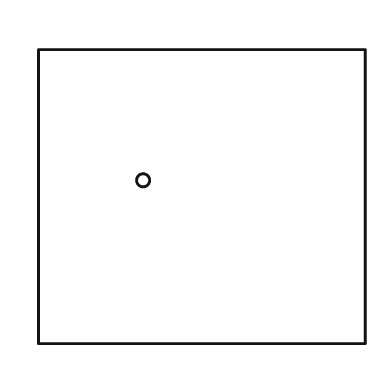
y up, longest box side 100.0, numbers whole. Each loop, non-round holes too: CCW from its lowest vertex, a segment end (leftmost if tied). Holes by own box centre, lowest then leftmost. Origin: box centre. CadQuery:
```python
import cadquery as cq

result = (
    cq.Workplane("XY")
    .moveTo(-50.0, -45.0)
    .lineTo(50.0, -45.0)
    .lineTo(50.0, 45.0)
    .lineTo(-50.0, 45.0)
    .close()
    .moveTo(-18.0, 5.0)
    .circle(2.0)
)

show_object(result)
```